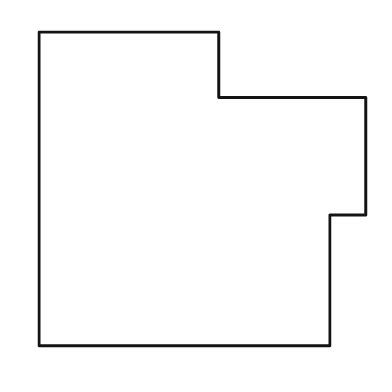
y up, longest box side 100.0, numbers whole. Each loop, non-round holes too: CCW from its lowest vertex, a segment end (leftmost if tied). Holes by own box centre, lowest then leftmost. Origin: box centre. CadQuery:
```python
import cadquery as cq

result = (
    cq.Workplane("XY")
    .moveTo(-50.0, -48.0)
    .lineTo(39.0, -48.0)
    .lineTo(39.0, -8.0)
    .lineTo(50.0, -8.0)
    .lineTo(50.0, 28.0)
    .lineTo(5.0, 28.0)
    .lineTo(5.0, 48.0)
    .lineTo(-50.0, 48.0)
    .close()
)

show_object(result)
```